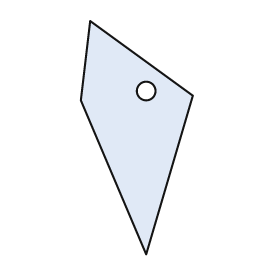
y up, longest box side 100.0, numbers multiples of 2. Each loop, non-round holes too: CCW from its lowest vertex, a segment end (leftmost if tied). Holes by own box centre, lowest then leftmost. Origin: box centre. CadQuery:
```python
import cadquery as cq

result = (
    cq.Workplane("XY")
    .moveTo(4.0, -50.0)
    .lineTo(24.0, 18.0)
    .lineTo(-20.0, 50.0)
    .lineTo(-24.0, 16.0)
    .close()
    .moveTo(4.0, 20.0)
    .circle(4.0)
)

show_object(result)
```